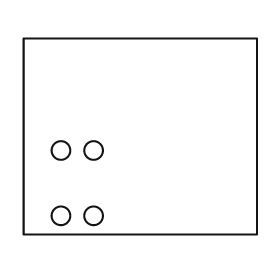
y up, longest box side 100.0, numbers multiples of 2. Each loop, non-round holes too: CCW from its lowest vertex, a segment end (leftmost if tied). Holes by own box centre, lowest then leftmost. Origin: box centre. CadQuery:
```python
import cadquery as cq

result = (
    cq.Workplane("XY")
    .moveTo(-50.0, -42.0)
    .lineTo(50.0, -42.0)
    .lineTo(50.0, 42.0)
    .lineTo(-50.0, 42.0)
    .close()
    .moveTo(-34.0, -34.0)
    .circle(4.0)
    .moveTo(-20.0, -34.0)
    .circle(4.0)
    .moveTo(-34.0, -6.0)
    .circle(4.0)
    .moveTo(-20.0, -6.0)
    .circle(4.0)
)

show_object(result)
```